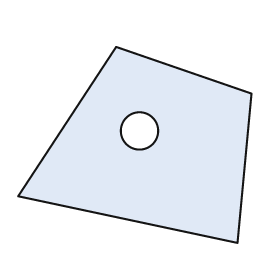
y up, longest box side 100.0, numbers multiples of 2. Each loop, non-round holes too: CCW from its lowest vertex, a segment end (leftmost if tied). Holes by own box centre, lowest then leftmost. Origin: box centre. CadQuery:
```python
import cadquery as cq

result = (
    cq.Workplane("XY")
    .moveTo(44.0, -42.0)
    .lineTo(50.0, 22.0)
    .lineTo(-8.0, 42.0)
    .lineTo(-50.0, -22.0)
    .close()
    .moveTo(2.0, 6.0)
    .circle(8.0)
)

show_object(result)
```